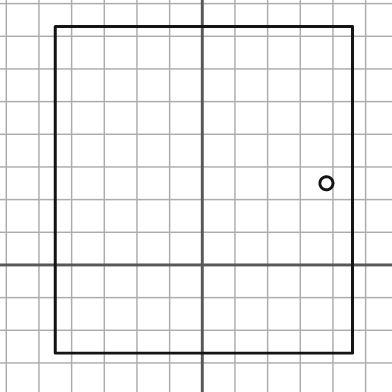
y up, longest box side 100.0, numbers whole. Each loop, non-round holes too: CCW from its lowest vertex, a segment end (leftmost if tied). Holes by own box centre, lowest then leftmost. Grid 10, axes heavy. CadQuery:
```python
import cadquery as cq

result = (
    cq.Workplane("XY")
    .moveTo(-45.0, -27.0)
    .lineTo(46.0, -27.0)
    .lineTo(46.0, 73.0)
    .lineTo(-45.0, 73.0)
    .close()
    .moveTo(38.0, 25.0)
    .circle(2.0)
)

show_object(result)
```